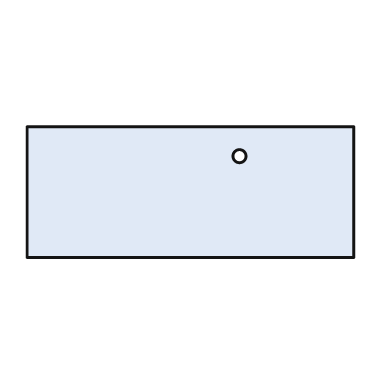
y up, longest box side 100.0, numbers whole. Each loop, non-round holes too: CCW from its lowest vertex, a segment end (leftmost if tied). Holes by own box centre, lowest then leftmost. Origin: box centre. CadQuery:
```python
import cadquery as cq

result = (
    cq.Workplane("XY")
    .moveTo(-50.0, -20.0)
    .lineTo(50.0, -20.0)
    .lineTo(50.0, 20.0)
    .lineTo(-50.0, 20.0)
    .close()
    .moveTo(15.0, 11.0)
    .circle(2.0)
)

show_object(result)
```